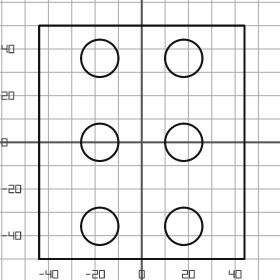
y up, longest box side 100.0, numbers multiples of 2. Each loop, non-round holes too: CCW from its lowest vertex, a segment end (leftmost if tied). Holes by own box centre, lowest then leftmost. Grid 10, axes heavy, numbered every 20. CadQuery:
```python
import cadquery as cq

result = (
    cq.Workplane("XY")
    .moveTo(-44.0, -50.0)
    .lineTo(44.0, -50.0)
    .lineTo(44.0, 50.0)
    .lineTo(-44.0, 50.0)
    .close()
    .moveTo(-18.0, -36.0)
    .circle(8.0)
    .moveTo(18.0, -36.0)
    .circle(8.0)
    .moveTo(-18.0, 0.0)
    .circle(8.0)
    .moveTo(18.0, 0.0)
    .circle(8.0)
    .moveTo(-18.0, 36.0)
    .circle(8.0)
    .moveTo(18.0, 36.0)
    .circle(8.0)
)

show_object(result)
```